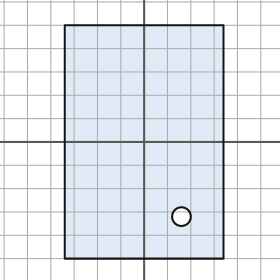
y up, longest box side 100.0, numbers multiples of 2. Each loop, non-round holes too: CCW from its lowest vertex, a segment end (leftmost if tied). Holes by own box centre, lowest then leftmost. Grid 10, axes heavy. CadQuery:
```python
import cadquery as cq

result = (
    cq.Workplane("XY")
    .moveTo(-34.0, -50.0)
    .lineTo(34.0, -50.0)
    .lineTo(34.0, 50.0)
    .lineTo(-34.0, 50.0)
    .close()
    .moveTo(16.0, -32.0)
    .circle(4.0)
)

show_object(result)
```